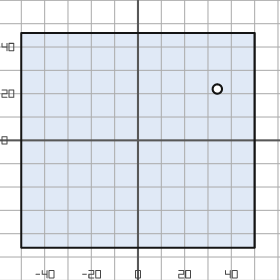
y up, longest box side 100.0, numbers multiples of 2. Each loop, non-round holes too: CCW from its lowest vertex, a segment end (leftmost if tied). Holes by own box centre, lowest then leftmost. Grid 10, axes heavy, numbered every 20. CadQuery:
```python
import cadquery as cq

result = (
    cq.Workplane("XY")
    .moveTo(-50.0, -46.0)
    .lineTo(50.0, -46.0)
    .lineTo(50.0, 46.0)
    .lineTo(-50.0, 46.0)
    .close()
    .moveTo(34.0, 22.0)
    .circle(2.0)
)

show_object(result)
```